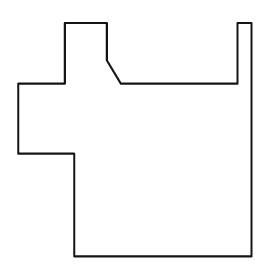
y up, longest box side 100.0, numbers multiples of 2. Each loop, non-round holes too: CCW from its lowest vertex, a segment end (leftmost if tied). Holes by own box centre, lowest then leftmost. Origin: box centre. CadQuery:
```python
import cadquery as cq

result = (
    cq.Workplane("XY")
    .moveTo(-26.0, -50.0)
    .lineTo(50.0, -50.0)
    .lineTo(50.0, 50.0)
    .lineTo(44.0, 50.0)
    .lineTo(44.0, 24.0)
    .lineTo(-6.0, 24.0)
    .lineTo(-12.0, 34.0)
    .lineTo(-12.0, 50.0)
    .lineTo(-30.0, 50.0)
    .lineTo(-30.0, 24.0)
    .lineTo(-50.0, 24.0)
    .lineTo(-50.0, -6.0)
    .lineTo(-26.0, -6.0)
    .close()
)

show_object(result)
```